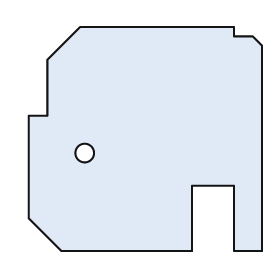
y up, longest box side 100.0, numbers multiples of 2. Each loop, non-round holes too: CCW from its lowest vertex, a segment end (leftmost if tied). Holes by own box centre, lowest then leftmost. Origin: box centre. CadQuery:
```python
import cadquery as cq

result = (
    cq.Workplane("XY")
    .moveTo(-36.0, -48.0)
    .lineTo(20.0, -48.0)
    .lineTo(20.0, -20.0)
    .lineTo(38.0, -20.0)
    .lineTo(38.0, -48.0)
    .lineTo(50.0, -48.0)
    .lineTo(50.0, 40.0)
    .lineTo(46.0, 44.0)
    .lineTo(38.0, 44.0)
    .lineTo(38.0, 48.0)
    .lineTo(-28.0, 48.0)
    .lineTo(-42.0, 34.0)
    .lineTo(-42.0, 10.0)
    .lineTo(-50.0, 10.0)
    .lineTo(-50.0, -34.0)
    .close()
    .moveTo(-26.0, -6.0)
    .circle(4.0)
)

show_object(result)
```